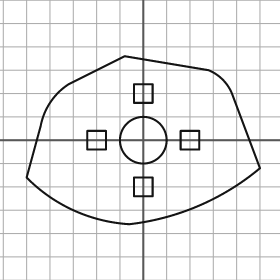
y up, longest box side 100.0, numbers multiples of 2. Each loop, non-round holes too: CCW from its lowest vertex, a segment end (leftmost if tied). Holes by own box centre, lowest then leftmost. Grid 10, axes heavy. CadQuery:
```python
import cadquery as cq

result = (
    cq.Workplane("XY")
    .moveTo(-6.0, -36.0)
    .threePointArc((24.0, -28.0), (50.0, -12.0))
    .lineTo(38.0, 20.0)
    .threePointArc((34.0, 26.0), (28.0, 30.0))
    .lineTo(-8.0, 36.0)
    .lineTo(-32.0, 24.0)
    .threePointArc((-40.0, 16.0), (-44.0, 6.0))
    .lineTo(-50.0, -16.0)
    .threePointArc((-30.0, -30.0), (-6.0, -36.0))
    .close()
    .moveTo(-4.0, -24.0)
    .lineTo(4.0, -24.0)
    .lineTo(4.0, -16.0)
    .lineTo(-4.0, -16.0)
    .close()
    .moveTo(-24.0, -4.0)
    .lineTo(-16.0, -4.0)
    .lineTo(-16.0, 4.0)
    .lineTo(-24.0, 4.0)
    .close()
    .moveTo(0.0, 0.0)
    .circle(10.0)
    .moveTo(16.0, -4.0)
    .lineTo(24.0, -4.0)
    .lineTo(24.0, 4.0)
    .lineTo(16.0, 4.0)
    .close()
    .moveTo(-4.0, 16.0)
    .lineTo(4.0, 16.0)
    .lineTo(4.0, 24.0)
    .lineTo(-4.0, 24.0)
    .close()
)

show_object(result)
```